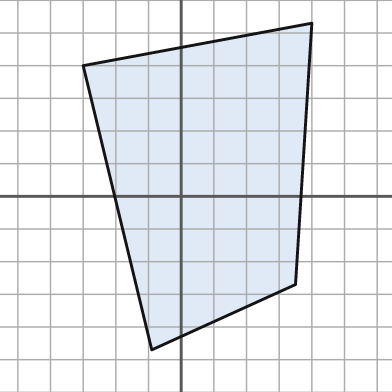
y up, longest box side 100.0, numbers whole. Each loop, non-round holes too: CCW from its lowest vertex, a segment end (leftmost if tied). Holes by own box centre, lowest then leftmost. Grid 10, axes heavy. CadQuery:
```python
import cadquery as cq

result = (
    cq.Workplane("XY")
    .moveTo(-9.0, -47.0)
    .lineTo(35.0, -27.0)
    .lineTo(40.0, 53.0)
    .lineTo(-30.0, 40.0)
    .close()
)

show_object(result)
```